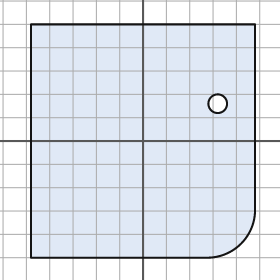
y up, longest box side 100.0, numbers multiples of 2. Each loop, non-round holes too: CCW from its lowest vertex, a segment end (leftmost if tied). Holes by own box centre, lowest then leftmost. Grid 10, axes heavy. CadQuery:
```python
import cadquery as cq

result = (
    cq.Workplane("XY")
    .moveTo(-48.0, -50.0)
    .lineTo(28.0, -50.0)
    .threePointArc((42.0, -44.0), (48.0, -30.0))
    .lineTo(48.0, 50.0)
    .lineTo(-48.0, 50.0)
    .close()
    .moveTo(32.0, 16.0)
    .circle(4.0)
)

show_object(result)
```